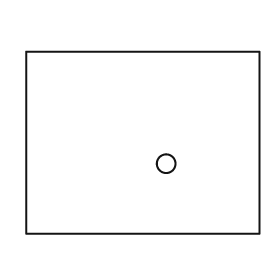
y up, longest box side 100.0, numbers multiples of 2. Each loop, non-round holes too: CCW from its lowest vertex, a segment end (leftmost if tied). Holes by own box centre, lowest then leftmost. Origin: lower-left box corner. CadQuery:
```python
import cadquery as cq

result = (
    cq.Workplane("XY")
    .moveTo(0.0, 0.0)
    .lineTo(100.0, 0.0)
    .lineTo(100.0, 78.0)
    .lineTo(0.0, 78.0)
    .close()
    .moveTo(60.0, 30.0)
    .circle(4.0)
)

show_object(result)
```